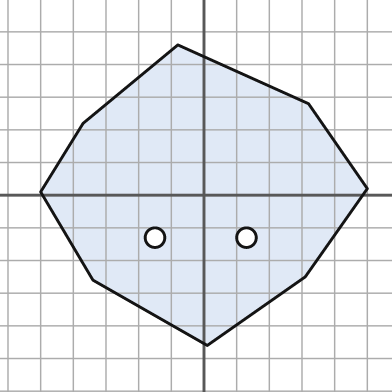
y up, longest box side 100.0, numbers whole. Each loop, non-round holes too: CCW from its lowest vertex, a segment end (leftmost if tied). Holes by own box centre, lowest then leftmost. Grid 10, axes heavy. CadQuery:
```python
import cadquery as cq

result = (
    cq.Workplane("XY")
    .moveTo(1.0, -46.0)
    .lineTo(31.0, -25.0)
    .lineTo(50.0, 2.0)
    .lineTo(32.0, 28.0)
    .lineTo(-8.0, 46.0)
    .lineTo(-37.0, 22.0)
    .lineTo(-50.0, 1.0)
    .lineTo(-34.0, -26.0)
    .close()
    .moveTo(-15.0, -13.0)
    .circle(3.0)
    .moveTo(13.0, -13.0)
    .circle(3.0)
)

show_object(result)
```